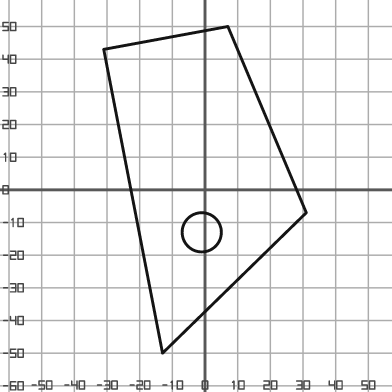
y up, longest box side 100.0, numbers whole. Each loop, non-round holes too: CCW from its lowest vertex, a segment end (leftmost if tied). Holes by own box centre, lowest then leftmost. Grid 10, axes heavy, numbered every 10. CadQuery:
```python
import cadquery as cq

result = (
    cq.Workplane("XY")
    .moveTo(-13.0, -50.0)
    .lineTo(31.0, -7.0)
    .lineTo(7.0, 50.0)
    .lineTo(-31.0, 43.0)
    .close()
    .moveTo(-1.0, -13.0)
    .circle(6.0)
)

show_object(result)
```